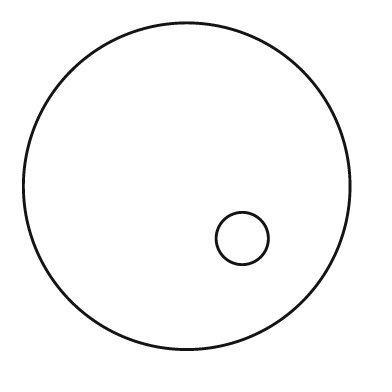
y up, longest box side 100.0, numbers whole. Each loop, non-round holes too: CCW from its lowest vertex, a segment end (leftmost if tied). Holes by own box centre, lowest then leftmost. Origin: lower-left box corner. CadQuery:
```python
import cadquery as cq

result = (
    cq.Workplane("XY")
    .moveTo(50.0, 50.0)
    .circle(50.0)
    .moveTo(67.0, 34.0)
    .circle(8.0)
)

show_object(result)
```